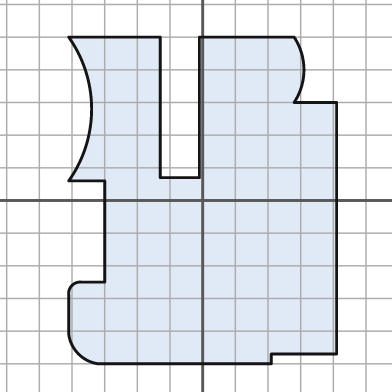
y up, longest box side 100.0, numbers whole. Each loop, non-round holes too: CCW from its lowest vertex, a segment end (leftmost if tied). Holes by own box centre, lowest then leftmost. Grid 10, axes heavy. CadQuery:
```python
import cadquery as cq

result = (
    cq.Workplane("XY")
    .moveTo(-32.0, -50.0)
    .lineTo(21.0, -50.0)
    .lineTo(21.0, -47.0)
    .lineTo(41.0, -47.0)
    .lineTo(41.0, 30.0)
    .lineTo(28.0, 30.0)
    .threePointArc((31.0, 40.0), (28.0, 50.0))
    .lineTo(-1.0, 50.0)
    .lineTo(-1.0, 7.0)
    .lineTo(-13.0, 7.0)
    .lineTo(-13.0, 50.0)
    .lineTo(-41.0, 50.0)
    .threePointArc((-34.0, 28.0), (-41.0, 6.0))
    .lineTo(-30.0, 6.0)
    .lineTo(-30.0, -25.0)
    .lineTo(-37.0, -25.0)
    .threePointArc((-40.0, -26.0), (-41.0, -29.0))
    .lineTo(-41.0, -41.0)
    .threePointArc((-38.0, -47.0), (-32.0, -50.0))
    .close()
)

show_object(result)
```